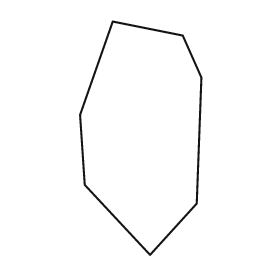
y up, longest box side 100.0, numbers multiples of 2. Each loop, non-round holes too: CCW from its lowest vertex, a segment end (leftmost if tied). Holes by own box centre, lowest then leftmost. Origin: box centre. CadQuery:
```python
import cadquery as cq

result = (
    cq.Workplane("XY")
    .moveTo(4.0, -50.0)
    .lineTo(24.0, -28.0)
    .lineTo(26.0, 26.0)
    .lineTo(18.0, 44.0)
    .lineTo(-12.0, 50.0)
    .lineTo(-26.0, 10.0)
    .lineTo(-24.0, -20.0)
    .close()
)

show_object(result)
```